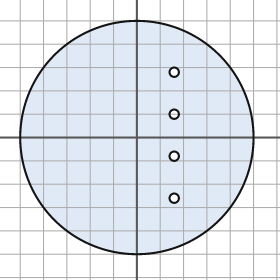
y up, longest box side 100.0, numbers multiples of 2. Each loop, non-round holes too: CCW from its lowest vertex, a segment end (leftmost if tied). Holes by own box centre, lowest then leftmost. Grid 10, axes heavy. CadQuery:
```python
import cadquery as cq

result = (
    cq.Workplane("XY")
    .moveTo(0.0, 0.0)
    .circle(50.0)
    .moveTo(16.0, -26.0)
    .circle(2.0)
    .moveTo(16.0, -8.0)
    .circle(2.0)
    .moveTo(16.0, 10.0)
    .circle(2.0)
    .moveTo(16.0, 28.0)
    .circle(2.0)
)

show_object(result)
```